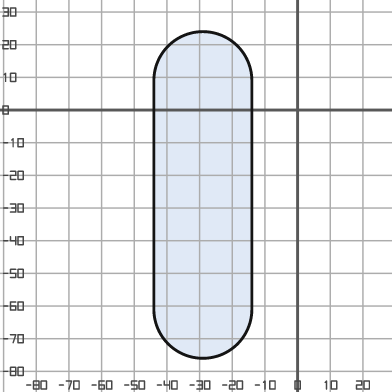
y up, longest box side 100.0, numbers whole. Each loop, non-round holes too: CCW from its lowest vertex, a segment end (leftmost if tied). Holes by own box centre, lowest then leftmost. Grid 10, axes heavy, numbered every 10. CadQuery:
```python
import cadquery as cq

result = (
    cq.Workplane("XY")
    .moveTo(-44.0, -61.0)
    .threePointArc((-29.0, -76.0), (-14.0, -61.0))
    .lineTo(-14.0, 9.0)
    .threePointArc((-29.0, 24.0), (-44.0, 9.0))
    .close()
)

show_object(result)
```